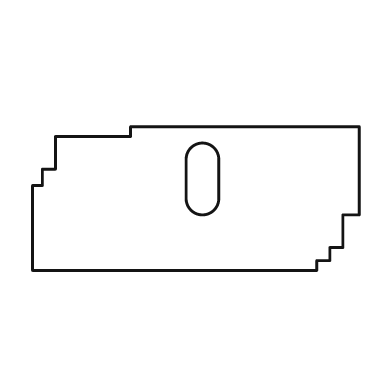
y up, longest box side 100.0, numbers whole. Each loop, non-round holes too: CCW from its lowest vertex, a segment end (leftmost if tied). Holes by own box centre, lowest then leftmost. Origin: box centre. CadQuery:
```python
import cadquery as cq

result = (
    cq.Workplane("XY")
    .moveTo(-50.0, -22.0)
    .lineTo(37.0, -22.0)
    .lineTo(37.0, -19.0)
    .lineTo(41.0, -19.0)
    .lineTo(41.0, -15.0)
    .lineTo(45.0, -15.0)
    .lineTo(45.0, -5.0)
    .lineTo(50.0, -5.0)
    .lineTo(50.0, 22.0)
    .lineTo(-20.0, 22.0)
    .lineTo(-20.0, 19.0)
    .lineTo(-43.0, 19.0)
    .lineTo(-43.0, 9.0)
    .lineTo(-47.0, 9.0)
    .lineTo(-47.0, 4.0)
    .lineTo(-50.0, 4.0)
    .close()
    .moveTo(-3.0, 0.0)
    .threePointArc((2.0, -5.0), (7.0, 0.0))
    .lineTo(7.0, 12.0)
    .threePointArc((2.0, 17.0), (-3.0, 12.0))
    .close()
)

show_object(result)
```